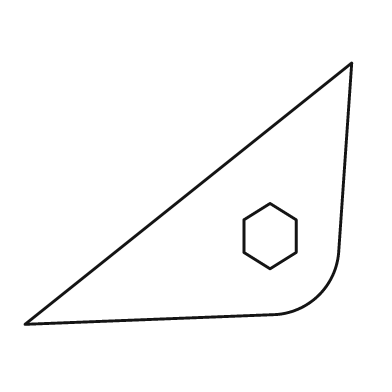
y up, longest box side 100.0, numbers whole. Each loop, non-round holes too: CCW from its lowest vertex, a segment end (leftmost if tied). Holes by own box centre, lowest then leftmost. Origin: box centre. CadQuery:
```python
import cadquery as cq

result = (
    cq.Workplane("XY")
    .moveTo(-50.0, -40.0)
    .lineTo(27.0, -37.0)
    .threePointArc((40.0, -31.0), (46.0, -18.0))
    .lineTo(50.0, 40.0)
    .close()
    .moveTo(25.0, -23.0)
    .lineTo(33.0, -18.0)
    .lineTo(33.0, -8.0)
    .lineTo(25.0, -3.0)
    .lineTo(17.0, -8.0)
    .lineTo(17.0, -18.0)
    .close()
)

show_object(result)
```